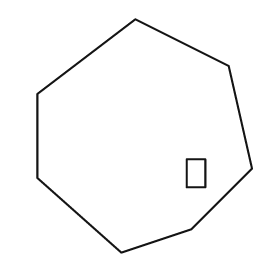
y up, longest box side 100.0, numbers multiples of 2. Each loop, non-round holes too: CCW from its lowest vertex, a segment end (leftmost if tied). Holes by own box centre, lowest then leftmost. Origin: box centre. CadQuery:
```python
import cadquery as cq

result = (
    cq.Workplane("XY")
    .moveTo(-10.0, -50.0)
    .lineTo(20.0, -40.0)
    .lineTo(46.0, -14.0)
    .lineTo(36.0, 30.0)
    .lineTo(-4.0, 50.0)
    .lineTo(-46.0, 18.0)
    .lineTo(-46.0, -18.0)
    .close()
    .moveTo(18.0, -22.0)
    .lineTo(26.0, -22.0)
    .lineTo(26.0, -10.0)
    .lineTo(18.0, -10.0)
    .close()
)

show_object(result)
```